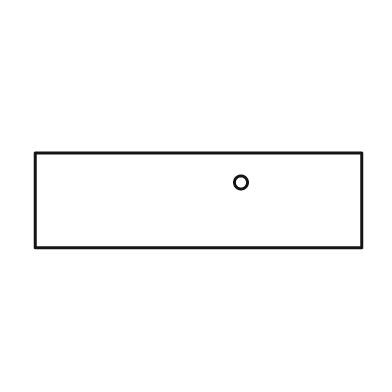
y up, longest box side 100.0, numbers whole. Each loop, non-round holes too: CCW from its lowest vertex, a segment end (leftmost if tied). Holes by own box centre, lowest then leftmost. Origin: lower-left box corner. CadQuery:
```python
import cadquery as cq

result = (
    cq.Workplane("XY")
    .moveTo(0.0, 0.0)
    .lineTo(100.0, 0.0)
    .lineTo(100.0, 29.0)
    .lineTo(0.0, 29.0)
    .close()
    .moveTo(63.0, 20.0)
    .circle(2.0)
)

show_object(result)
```